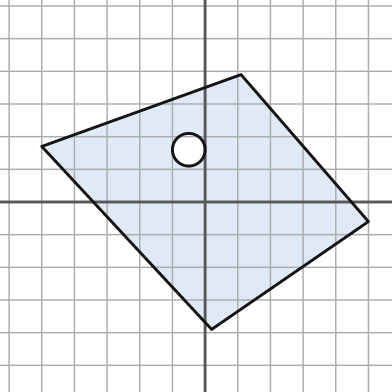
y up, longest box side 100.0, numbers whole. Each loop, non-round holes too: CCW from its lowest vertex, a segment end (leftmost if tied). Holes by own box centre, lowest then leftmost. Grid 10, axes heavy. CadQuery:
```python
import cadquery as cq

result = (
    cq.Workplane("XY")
    .moveTo(2.0, -39.0)
    .lineTo(50.0, -6.0)
    .lineTo(11.0, 39.0)
    .lineTo(-50.0, 17.0)
    .close()
    .moveTo(-5.0, 16.0)
    .circle(5.0)
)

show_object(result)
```